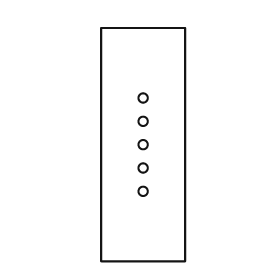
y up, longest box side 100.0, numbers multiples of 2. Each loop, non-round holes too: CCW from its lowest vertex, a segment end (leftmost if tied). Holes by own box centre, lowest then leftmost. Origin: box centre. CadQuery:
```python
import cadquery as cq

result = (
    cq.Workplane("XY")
    .moveTo(-18.0, -50.0)
    .lineTo(18.0, -50.0)
    .lineTo(18.0, 50.0)
    .lineTo(-18.0, 50.0)
    .close()
    .moveTo(0.0, -20.0)
    .circle(2.0)
    .moveTo(0.0, -10.0)
    .circle(2.0)
    .moveTo(0.0, 0.0)
    .circle(2.0)
    .moveTo(0.0, 10.0)
    .circle(2.0)
    .moveTo(0.0, 20.0)
    .circle(2.0)
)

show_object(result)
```